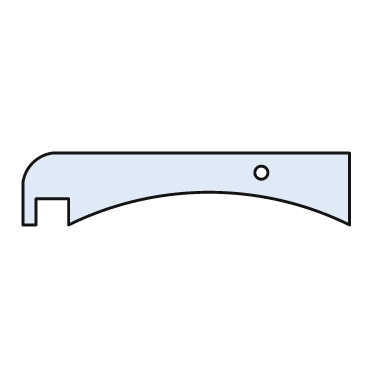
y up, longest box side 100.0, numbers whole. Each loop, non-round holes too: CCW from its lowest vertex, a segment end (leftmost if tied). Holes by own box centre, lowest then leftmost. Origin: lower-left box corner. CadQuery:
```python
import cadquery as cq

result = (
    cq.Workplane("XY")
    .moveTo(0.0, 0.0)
    .lineTo(4.0, 0.0)
    .lineTo(4.0, 8.0)
    .lineTo(14.0, 8.0)
    .lineTo(14.0, 0.0)
    .threePointArc((57.0, 10.0), (100.0, 0.0))
    .lineTo(100.0, 22.0)
    .lineTo(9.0, 22.0)
    .threePointArc((3.0, 19.0), (0.0, 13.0))
    .close()
    .moveTo(73.0, 16.0)
    .circle(2.0)
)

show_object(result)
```